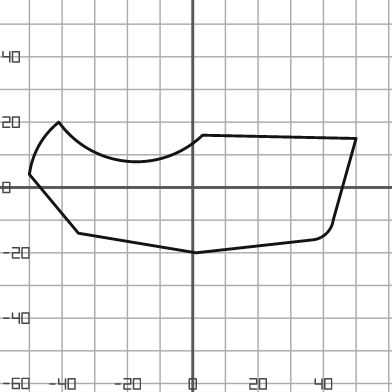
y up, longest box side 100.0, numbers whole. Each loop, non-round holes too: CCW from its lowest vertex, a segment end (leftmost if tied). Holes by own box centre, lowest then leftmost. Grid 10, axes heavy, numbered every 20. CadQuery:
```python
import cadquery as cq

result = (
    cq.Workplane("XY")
    .moveTo(1.0, -20.0)
    .lineTo(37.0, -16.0)
    .threePointArc((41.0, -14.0), (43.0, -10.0))
    .lineTo(50.0, 15.0)
    .lineTo(3.0, 16.0)
    .threePointArc((-20.0, 8.0), (-41.0, 20.0))
    .threePointArc((-47.0, 13.0), (-50.0, 4.0))
    .lineTo(-35.0, -14.0)
    .close()
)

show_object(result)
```